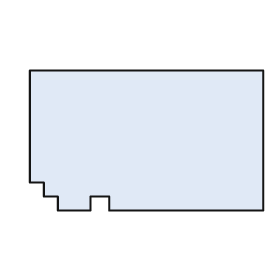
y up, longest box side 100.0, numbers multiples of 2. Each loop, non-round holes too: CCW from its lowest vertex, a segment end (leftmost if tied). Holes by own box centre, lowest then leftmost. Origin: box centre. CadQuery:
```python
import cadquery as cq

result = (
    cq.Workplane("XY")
    .moveTo(-38.0, -30.0)
    .lineTo(-24.0, -30.0)
    .lineTo(-24.0, -24.0)
    .lineTo(-16.0, -24.0)
    .lineTo(-16.0, -30.0)
    .lineTo(50.0, -30.0)
    .lineTo(50.0, 30.0)
    .lineTo(-50.0, 30.0)
    .lineTo(-50.0, -18.0)
    .lineTo(-44.0, -18.0)
    .lineTo(-44.0, -24.0)
    .lineTo(-38.0, -24.0)
    .close()
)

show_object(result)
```